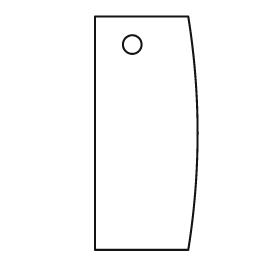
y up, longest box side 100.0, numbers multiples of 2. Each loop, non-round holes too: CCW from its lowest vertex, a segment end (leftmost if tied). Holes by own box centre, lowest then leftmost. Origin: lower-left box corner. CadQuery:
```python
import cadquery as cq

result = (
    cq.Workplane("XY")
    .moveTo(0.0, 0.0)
    .lineTo(40.0, 0.0)
    .threePointArc((44.0, 50.0), (40.0, 100.0))
    .lineTo(0.0, 100.0)
    .close()
    .moveTo(16.0, 88.0)
    .circle(4.0)
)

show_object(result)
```